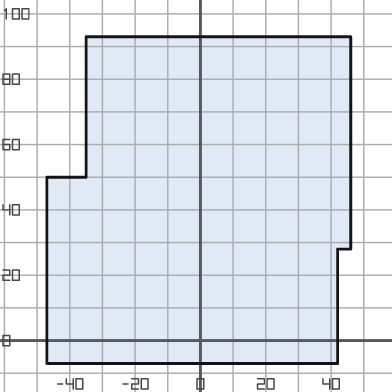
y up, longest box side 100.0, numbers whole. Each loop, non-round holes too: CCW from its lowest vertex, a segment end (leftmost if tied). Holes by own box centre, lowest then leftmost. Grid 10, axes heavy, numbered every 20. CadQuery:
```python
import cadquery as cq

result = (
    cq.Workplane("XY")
    .moveTo(-47.0, -7.0)
    .lineTo(42.0, -7.0)
    .lineTo(42.0, 28.0)
    .lineTo(46.0, 28.0)
    .lineTo(46.0, 93.0)
    .lineTo(-35.0, 93.0)
    .lineTo(-35.0, 50.0)
    .lineTo(-47.0, 50.0)
    .close()
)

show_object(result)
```